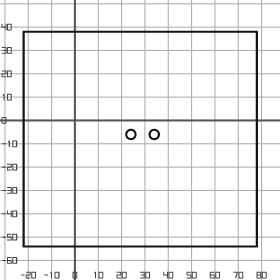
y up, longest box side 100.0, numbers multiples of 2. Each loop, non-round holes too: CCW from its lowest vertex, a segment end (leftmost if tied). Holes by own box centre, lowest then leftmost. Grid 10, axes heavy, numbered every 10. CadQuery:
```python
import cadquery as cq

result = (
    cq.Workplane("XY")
    .moveTo(-22.0, -54.0)
    .lineTo(78.0, -54.0)
    .lineTo(78.0, 38.0)
    .lineTo(-22.0, 38.0)
    .close()
    .moveTo(24.0, -6.0)
    .circle(2.0)
    .moveTo(34.0, -6.0)
    .circle(2.0)
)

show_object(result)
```